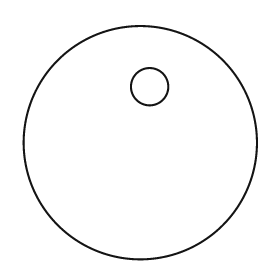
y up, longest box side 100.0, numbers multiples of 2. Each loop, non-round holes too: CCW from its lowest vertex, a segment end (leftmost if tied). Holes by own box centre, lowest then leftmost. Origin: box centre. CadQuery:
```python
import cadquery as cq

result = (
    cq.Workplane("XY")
    .moveTo(0.0, 0.0)
    .circle(50.0)
    .moveTo(4.0, 24.0)
    .circle(8.0)
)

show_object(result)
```